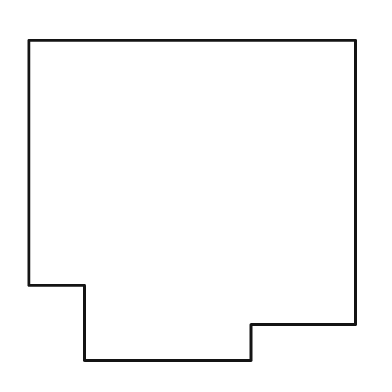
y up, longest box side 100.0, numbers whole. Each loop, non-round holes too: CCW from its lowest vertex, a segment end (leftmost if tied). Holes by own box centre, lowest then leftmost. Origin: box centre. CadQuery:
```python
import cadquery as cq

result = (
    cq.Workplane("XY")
    .moveTo(-33.0, -49.0)
    .lineTo(18.0, -49.0)
    .lineTo(18.0, -38.0)
    .lineTo(50.0, -38.0)
    .lineTo(50.0, 49.0)
    .lineTo(-50.0, 49.0)
    .lineTo(-50.0, -26.0)
    .lineTo(-33.0, -26.0)
    .close()
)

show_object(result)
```